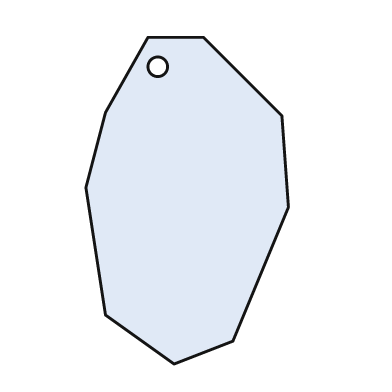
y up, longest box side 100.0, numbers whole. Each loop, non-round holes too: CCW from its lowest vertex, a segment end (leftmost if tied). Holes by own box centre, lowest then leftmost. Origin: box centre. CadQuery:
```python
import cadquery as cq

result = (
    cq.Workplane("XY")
    .moveTo(-4.0, -50.0)
    .lineTo(14.0, -43.0)
    .lineTo(31.0, -2.0)
    .lineTo(29.0, 26.0)
    .lineTo(5.0, 50.0)
    .lineTo(-12.0, 50.0)
    .lineTo(-25.0, 27.0)
    .lineTo(-31.0, 4.0)
    .lineTo(-25.0, -35.0)
    .close()
    .moveTo(-9.0, 41.0)
    .circle(3.0)
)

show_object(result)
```